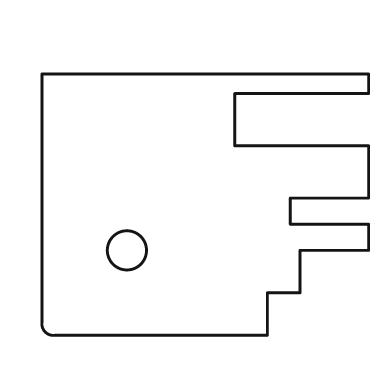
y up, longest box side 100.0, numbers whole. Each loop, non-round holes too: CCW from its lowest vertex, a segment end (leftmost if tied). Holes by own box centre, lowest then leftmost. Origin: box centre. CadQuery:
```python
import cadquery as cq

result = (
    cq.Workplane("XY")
    .moveTo(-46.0, -40.0)
    .lineTo(19.0, -40.0)
    .lineTo(19.0, -27.0)
    .lineTo(29.0, -27.0)
    .lineTo(29.0, -14.0)
    .lineTo(50.0, -14.0)
    .lineTo(50.0, -6.0)
    .lineTo(26.0, -6.0)
    .lineTo(26.0, 2.0)
    .lineTo(50.0, 2.0)
    .lineTo(50.0, 18.0)
    .lineTo(9.0, 18.0)
    .lineTo(9.0, 34.0)
    .lineTo(50.0, 34.0)
    .lineTo(50.0, 40.0)
    .lineTo(-50.0, 40.0)
    .lineTo(-50.0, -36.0)
    .threePointArc((-49.0, -39.0), (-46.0, -40.0))
    .close()
    .moveTo(-24.0, -14.0)
    .circle(6.0)
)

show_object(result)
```